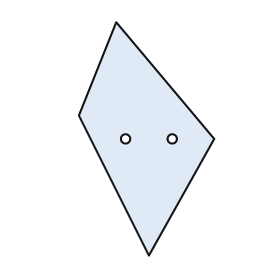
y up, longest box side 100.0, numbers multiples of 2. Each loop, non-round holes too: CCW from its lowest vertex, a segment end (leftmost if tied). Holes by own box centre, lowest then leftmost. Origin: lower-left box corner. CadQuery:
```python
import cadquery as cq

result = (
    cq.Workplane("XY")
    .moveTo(30.0, 0.0)
    .lineTo(58.0, 50.0)
    .lineTo(16.0, 100.0)
    .lineTo(0.0, 60.0)
    .close()
    .moveTo(20.0, 50.0)
    .circle(2.0)
    .moveTo(40.0, 50.0)
    .circle(2.0)
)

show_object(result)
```